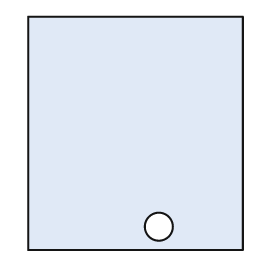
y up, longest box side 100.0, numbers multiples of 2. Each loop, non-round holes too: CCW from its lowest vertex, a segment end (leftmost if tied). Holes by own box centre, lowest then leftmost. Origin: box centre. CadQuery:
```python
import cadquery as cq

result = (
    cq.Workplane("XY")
    .moveTo(-46.0, -50.0)
    .lineTo(46.0, -50.0)
    .lineTo(46.0, 50.0)
    .lineTo(-46.0, 50.0)
    .close()
    .moveTo(10.0, -40.0)
    .circle(6.0)
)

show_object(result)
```